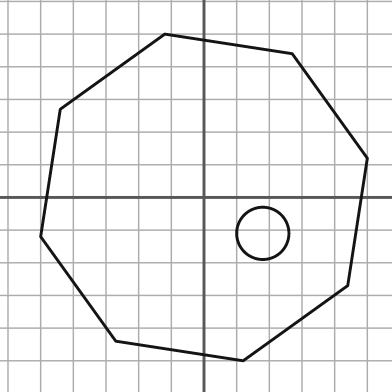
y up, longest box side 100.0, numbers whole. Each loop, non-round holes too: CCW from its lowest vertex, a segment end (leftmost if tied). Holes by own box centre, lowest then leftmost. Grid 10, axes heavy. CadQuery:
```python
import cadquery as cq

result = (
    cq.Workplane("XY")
    .moveTo(12.0, -50.0)
    .lineTo(44.0, -27.0)
    .lineTo(50.0, 12.0)
    .lineTo(27.0, 44.0)
    .lineTo(-12.0, 50.0)
    .lineTo(-44.0, 27.0)
    .lineTo(-50.0, -12.0)
    .lineTo(-27.0, -44.0)
    .close()
    .moveTo(18.0, -11.0)
    .circle(8.0)
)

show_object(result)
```